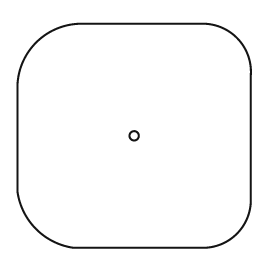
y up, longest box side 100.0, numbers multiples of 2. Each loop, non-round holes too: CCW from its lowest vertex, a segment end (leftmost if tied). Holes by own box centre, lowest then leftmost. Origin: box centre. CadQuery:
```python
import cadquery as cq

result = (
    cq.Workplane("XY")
    .moveTo(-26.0, -48.0)
    .lineTo(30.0, -48.0)
    .threePointArc((44.0, -42.0), (50.0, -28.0))
    .lineTo(50.0, 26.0)
    .threePointArc((44.0, 42.0), (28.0, 48.0))
    .lineTo(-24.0, 48.0)
    .threePointArc((-42.0, 40.0), (-50.0, 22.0))
    .lineTo(-50.0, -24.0)
    .threePointArc((-42.0, -40.0), (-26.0, -48.0))
    .close()
    .moveTo(0.0, 0.0)
    .circle(2.0)
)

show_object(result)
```